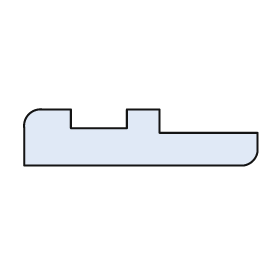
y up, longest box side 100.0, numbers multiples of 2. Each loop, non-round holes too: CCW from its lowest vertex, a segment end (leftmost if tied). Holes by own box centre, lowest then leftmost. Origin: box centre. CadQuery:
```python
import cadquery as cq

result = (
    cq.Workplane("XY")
    .moveTo(-50.0, -12.0)
    .lineTo(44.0, -12.0)
    .threePointArc((48.0, -10.0), (50.0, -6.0))
    .lineTo(50.0, 2.0)
    .lineTo(8.0, 2.0)
    .lineTo(8.0, 12.0)
    .lineTo(-6.0, 12.0)
    .lineTo(-6.0, 4.0)
    .lineTo(-30.0, 4.0)
    .lineTo(-30.0, 12.0)
    .lineTo(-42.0, 12.0)
    .threePointArc((-48.0, 10.0), (-50.0, 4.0))
    .close()
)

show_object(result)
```